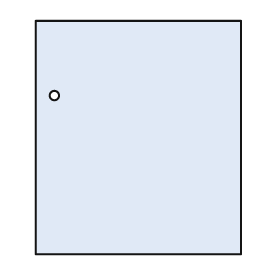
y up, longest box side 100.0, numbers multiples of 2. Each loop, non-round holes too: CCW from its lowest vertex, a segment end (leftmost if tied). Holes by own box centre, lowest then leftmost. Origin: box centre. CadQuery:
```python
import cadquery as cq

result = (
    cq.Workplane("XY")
    .moveTo(-44.0, -50.0)
    .lineTo(44.0, -50.0)
    .lineTo(44.0, 50.0)
    .lineTo(-44.0, 50.0)
    .close()
    .moveTo(-36.0, 18.0)
    .circle(2.0)
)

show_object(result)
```